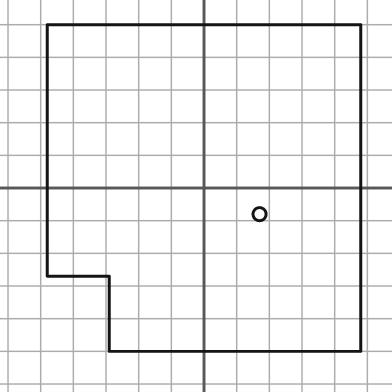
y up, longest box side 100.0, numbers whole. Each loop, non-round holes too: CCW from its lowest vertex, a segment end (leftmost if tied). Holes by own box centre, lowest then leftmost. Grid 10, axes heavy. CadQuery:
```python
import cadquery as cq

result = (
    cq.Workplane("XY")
    .moveTo(-29.0, -50.0)
    .lineTo(48.0, -50.0)
    .lineTo(48.0, 50.0)
    .lineTo(-48.0, 50.0)
    .lineTo(-48.0, -27.0)
    .lineTo(-29.0, -27.0)
    .close()
    .moveTo(17.0, -8.0)
    .circle(2.0)
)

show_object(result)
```